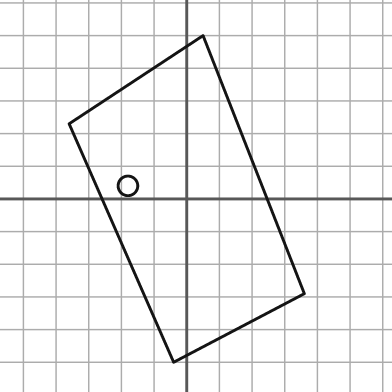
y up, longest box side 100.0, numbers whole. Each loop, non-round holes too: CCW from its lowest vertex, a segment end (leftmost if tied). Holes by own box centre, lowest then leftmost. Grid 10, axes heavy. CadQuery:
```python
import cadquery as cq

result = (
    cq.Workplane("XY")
    .moveTo(-4.0, -50.0)
    .lineTo(36.0, -29.0)
    .lineTo(5.0, 50.0)
    .lineTo(-36.0, 23.0)
    .close()
    .moveTo(-18.0, 4.0)
    .circle(3.0)
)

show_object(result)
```